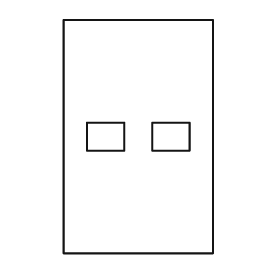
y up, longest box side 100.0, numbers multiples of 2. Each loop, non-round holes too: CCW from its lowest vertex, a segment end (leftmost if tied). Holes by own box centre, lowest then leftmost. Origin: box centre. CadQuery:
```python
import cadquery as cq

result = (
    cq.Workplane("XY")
    .moveTo(-32.0, -50.0)
    .lineTo(32.0, -50.0)
    .lineTo(32.0, 50.0)
    .lineTo(-32.0, 50.0)
    .close()
    .moveTo(-22.0, -6.0)
    .lineTo(-6.0, -6.0)
    .lineTo(-6.0, 6.0)
    .lineTo(-22.0, 6.0)
    .close()
    .moveTo(6.0, -6.0)
    .lineTo(22.0, -6.0)
    .lineTo(22.0, 6.0)
    .lineTo(6.0, 6.0)
    .close()
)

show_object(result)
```